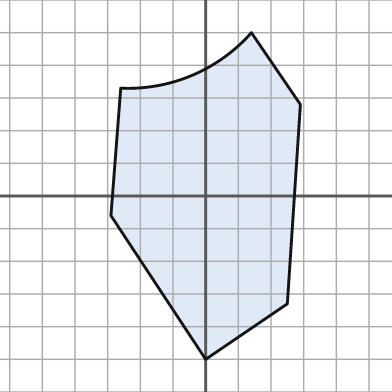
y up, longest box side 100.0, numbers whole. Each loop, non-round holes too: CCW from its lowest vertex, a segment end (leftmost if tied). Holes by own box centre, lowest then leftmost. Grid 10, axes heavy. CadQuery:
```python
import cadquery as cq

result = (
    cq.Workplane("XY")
    .moveTo(0.0, -50.0)
    .lineTo(25.0, -33.0)
    .lineTo(29.0, 28.0)
    .lineTo(14.0, 50.0)
    .threePointArc((-4.0, 37.0), (-26.0, 33.0))
    .lineTo(-29.0, -6.0)
    .close()
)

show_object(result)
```